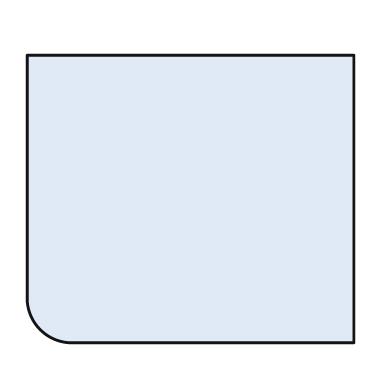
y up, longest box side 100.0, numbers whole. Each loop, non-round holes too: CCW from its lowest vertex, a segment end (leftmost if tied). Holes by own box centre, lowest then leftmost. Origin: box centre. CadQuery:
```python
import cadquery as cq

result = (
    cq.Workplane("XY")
    .moveTo(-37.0, -44.0)
    .lineTo(50.0, -44.0)
    .lineTo(50.0, 44.0)
    .lineTo(-50.0, 44.0)
    .lineTo(-50.0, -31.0)
    .threePointArc((-46.0, -40.0), (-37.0, -44.0))
    .close()
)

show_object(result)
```